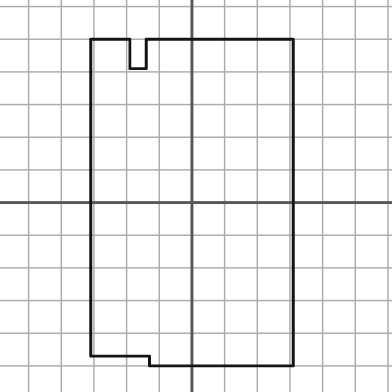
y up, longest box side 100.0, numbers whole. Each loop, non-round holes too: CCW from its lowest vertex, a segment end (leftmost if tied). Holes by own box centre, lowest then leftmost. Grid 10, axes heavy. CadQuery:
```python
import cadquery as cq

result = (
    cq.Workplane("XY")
    .moveTo(-13.0, -50.0)
    .lineTo(31.0, -50.0)
    .lineTo(31.0, 50.0)
    .lineTo(-14.0, 50.0)
    .lineTo(-14.0, 41.0)
    .lineTo(-19.0, 41.0)
    .lineTo(-19.0, 50.0)
    .lineTo(-31.0, 50.0)
    .lineTo(-31.0, -47.0)
    .lineTo(-13.0, -47.0)
    .close()
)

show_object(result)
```